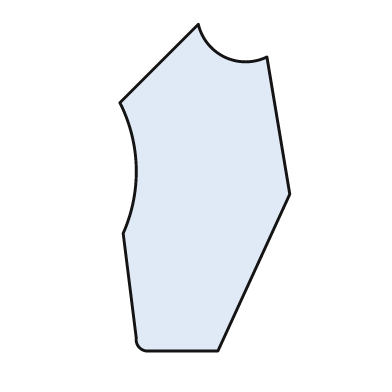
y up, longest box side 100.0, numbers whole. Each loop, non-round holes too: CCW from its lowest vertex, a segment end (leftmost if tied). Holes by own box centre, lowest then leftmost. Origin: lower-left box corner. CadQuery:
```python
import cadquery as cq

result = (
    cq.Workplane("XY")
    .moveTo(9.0, 0.0)
    .lineTo(30.0, 0.0)
    .lineTo(52.0, 48.0)
    .lineTo(45.0, 90.0)
    .threePointArc((32.0, 90.0), (24.0, 100.0))
    .lineTo(0.0, 76.0)
    .threePointArc((5.0, 56.0), (1.0, 36.0))
    .lineTo(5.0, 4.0)
    .threePointArc((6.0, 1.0), (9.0, 0.0))
    .close()
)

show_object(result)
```